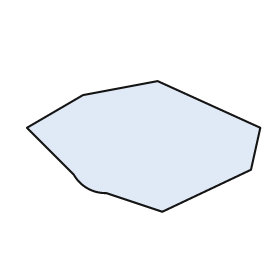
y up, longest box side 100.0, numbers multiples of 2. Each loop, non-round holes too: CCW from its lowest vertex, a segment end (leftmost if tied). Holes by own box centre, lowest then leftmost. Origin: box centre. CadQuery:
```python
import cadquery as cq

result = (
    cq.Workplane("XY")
    .moveTo(8.0, -28.0)
    .lineTo(46.0, -10.0)
    .lineTo(50.0, 8.0)
    .lineTo(6.0, 28.0)
    .lineTo(-26.0, 22.0)
    .lineTo(-50.0, 8.0)
    .lineTo(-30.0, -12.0)
    .threePointArc((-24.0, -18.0), (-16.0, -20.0))
    .close()
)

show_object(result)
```